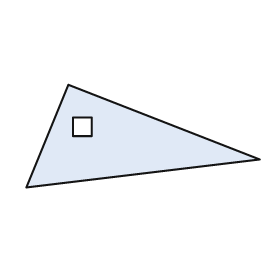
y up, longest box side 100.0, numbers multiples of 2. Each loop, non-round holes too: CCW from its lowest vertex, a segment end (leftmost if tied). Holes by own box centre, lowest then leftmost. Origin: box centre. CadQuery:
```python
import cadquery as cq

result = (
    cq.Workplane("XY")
    .moveTo(-50.0, -22.0)
    .lineTo(50.0, -10.0)
    .lineTo(-32.0, 22.0)
    .close()
    .moveTo(-30.0, 0.0)
    .lineTo(-22.0, 0.0)
    .lineTo(-22.0, 8.0)
    .lineTo(-30.0, 8.0)
    .close()
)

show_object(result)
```